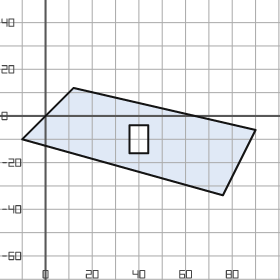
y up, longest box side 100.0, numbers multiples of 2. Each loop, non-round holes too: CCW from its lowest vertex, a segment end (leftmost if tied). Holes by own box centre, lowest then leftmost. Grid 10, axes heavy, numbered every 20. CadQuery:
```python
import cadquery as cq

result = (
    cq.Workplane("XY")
    .moveTo(76.0, -34.0)
    .lineTo(90.0, -6.0)
    .lineTo(12.0, 12.0)
    .lineTo(-10.0, -10.0)
    .close()
    .moveTo(36.0, -16.0)
    .lineTo(44.0, -16.0)
    .lineTo(44.0, -4.0)
    .lineTo(36.0, -4.0)
    .close()
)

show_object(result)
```